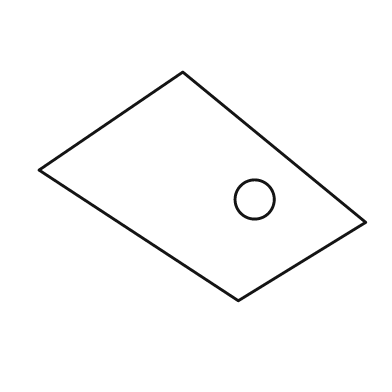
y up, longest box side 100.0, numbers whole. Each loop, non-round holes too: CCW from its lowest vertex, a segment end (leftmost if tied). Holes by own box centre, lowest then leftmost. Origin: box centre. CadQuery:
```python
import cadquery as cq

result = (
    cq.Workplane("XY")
    .moveTo(11.0, -35.0)
    .lineTo(50.0, -11.0)
    .lineTo(-6.0, 35.0)
    .lineTo(-50.0, 5.0)
    .close()
    .moveTo(16.0, -4.0)
    .circle(6.0)
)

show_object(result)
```